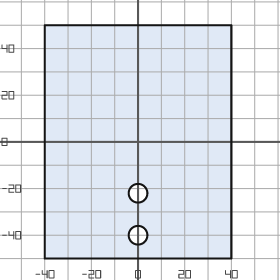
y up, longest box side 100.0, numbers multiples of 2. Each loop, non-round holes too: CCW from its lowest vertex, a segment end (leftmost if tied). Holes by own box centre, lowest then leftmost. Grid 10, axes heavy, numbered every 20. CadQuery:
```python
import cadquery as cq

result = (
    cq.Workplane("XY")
    .moveTo(-40.0, -50.0)
    .lineTo(40.0, -50.0)
    .lineTo(40.0, 50.0)
    .lineTo(-40.0, 50.0)
    .close()
    .moveTo(0.0, -40.0)
    .circle(4.0)
    .moveTo(0.0, -22.0)
    .circle(4.0)
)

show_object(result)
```